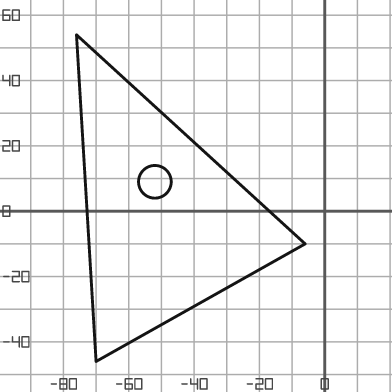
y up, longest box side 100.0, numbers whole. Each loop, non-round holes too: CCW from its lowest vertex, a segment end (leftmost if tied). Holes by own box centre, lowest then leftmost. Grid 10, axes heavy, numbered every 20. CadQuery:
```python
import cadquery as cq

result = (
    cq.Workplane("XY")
    .moveTo(-70.0, -46.0)
    .lineTo(-6.0, -10.0)
    .lineTo(-76.0, 54.0)
    .close()
    .moveTo(-52.0, 9.0)
    .circle(5.0)
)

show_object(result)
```